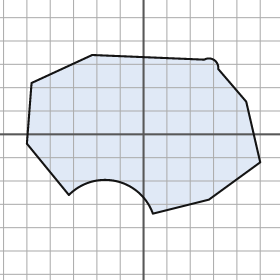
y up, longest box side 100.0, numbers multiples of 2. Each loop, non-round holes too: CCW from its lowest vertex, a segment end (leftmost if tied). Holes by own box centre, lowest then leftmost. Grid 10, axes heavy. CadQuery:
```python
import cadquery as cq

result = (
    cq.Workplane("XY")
    .moveTo(4.0, -34.0)
    .lineTo(28.0, -28.0)
    .lineTo(50.0, -12.0)
    .lineTo(44.0, 14.0)
    .lineTo(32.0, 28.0)
    .threePointArc((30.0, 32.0), (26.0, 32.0))
    .lineTo(-22.0, 34.0)
    .lineTo(-48.0, 22.0)
    .lineTo(-50.0, -4.0)
    .lineTo(-32.0, -26.0)
    .threePointArc((-12.0, -20.0), (4.0, -34.0))
    .close()
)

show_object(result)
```